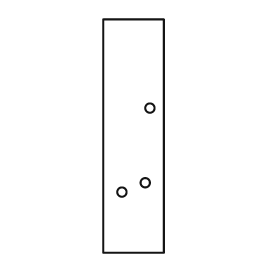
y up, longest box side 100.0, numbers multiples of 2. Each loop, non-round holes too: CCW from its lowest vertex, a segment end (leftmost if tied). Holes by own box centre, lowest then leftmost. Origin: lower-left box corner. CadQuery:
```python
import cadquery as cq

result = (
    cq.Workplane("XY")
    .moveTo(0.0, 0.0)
    .lineTo(26.0, 0.0)
    .lineTo(26.0, 100.0)
    .lineTo(0.0, 100.0)
    .close()
    .moveTo(8.0, 26.0)
    .circle(2.0)
    .moveTo(18.0, 30.0)
    .circle(2.0)
    .moveTo(20.0, 62.0)
    .circle(2.0)
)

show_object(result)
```